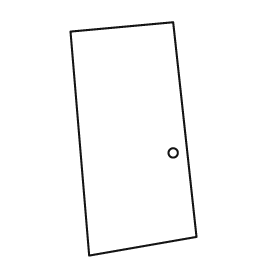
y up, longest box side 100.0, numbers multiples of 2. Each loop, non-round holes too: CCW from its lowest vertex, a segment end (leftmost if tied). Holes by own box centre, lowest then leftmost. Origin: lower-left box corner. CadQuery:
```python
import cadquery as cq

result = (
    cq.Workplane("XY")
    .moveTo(8.0, 0.0)
    .lineTo(54.0, 8.0)
    .lineTo(44.0, 100.0)
    .lineTo(0.0, 96.0)
    .close()
    .moveTo(44.0, 44.0)
    .circle(2.0)
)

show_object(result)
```